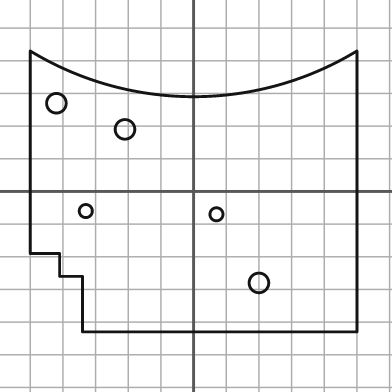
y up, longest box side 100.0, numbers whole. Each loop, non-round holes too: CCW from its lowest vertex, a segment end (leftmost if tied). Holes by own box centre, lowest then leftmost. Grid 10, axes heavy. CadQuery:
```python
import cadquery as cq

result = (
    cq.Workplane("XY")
    .moveTo(-34.0, -43.0)
    .lineTo(50.0, -43.0)
    .lineTo(50.0, 43.0)
    .threePointArc((0.0, 29.0), (-50.0, 43.0))
    .lineTo(-50.0, -19.0)
    .lineTo(-41.0, -19.0)
    .lineTo(-41.0, -26.0)
    .lineTo(-34.0, -26.0)
    .close()
    .moveTo(20.0, -28.0)
    .circle(3.0)
    .moveTo(7.0, -7.0)
    .circle(2.0)
    .moveTo(-33.0, -6.0)
    .circle(2.0)
    .moveTo(-21.0, 19.0)
    .circle(3.0)
    .moveTo(-42.0, 27.0)
    .circle(3.0)
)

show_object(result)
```